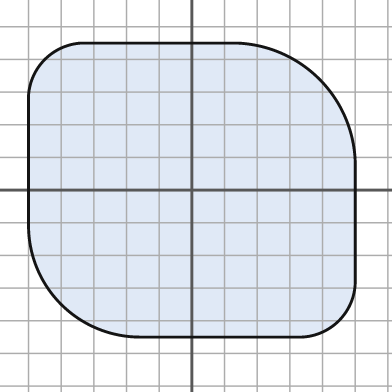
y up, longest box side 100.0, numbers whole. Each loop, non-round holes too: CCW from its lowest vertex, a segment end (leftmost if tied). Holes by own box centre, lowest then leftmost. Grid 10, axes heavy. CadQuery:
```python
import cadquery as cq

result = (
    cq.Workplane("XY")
    .moveTo(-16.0, -45.0)
    .lineTo(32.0, -45.0)
    .threePointArc((45.0, -40.0), (50.0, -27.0))
    .lineTo(50.0, 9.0)
    .threePointArc((39.0, 34.0), (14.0, 45.0))
    .lineTo(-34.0, 45.0)
    .threePointArc((-45.0, 40.0), (-50.0, 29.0))
    .lineTo(-50.0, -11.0)
    .threePointArc((-40.0, -35.0), (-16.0, -45.0))
    .close()
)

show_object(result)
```